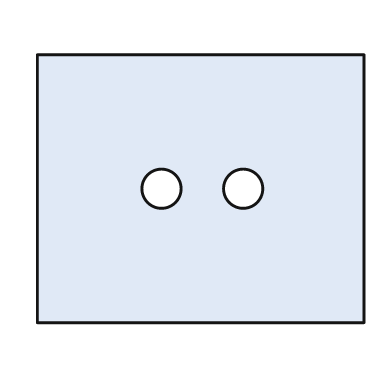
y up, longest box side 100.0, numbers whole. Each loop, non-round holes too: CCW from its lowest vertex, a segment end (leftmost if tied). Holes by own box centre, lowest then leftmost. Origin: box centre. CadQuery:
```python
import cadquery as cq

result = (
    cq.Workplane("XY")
    .moveTo(-50.0, -41.0)
    .lineTo(50.0, -41.0)
    .lineTo(50.0, 41.0)
    .lineTo(-50.0, 41.0)
    .close()
    .moveTo(-12.0, 0.0)
    .circle(6.0)
    .moveTo(13.0, 0.0)
    .circle(6.0)
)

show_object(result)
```